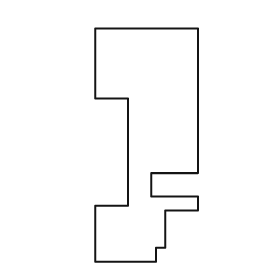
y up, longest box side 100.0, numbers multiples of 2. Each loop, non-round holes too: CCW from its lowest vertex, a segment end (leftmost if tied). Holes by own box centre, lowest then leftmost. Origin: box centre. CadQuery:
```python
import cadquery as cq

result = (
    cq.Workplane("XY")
    .moveTo(-22.0, -50.0)
    .lineTo(4.0, -50.0)
    .lineTo(4.0, -44.0)
    .lineTo(8.0, -44.0)
    .lineTo(8.0, -28.0)
    .lineTo(22.0, -28.0)
    .lineTo(22.0, -22.0)
    .lineTo(2.0, -22.0)
    .lineTo(2.0, -12.0)
    .lineTo(22.0, -12.0)
    .lineTo(22.0, 50.0)
    .lineTo(-22.0, 50.0)
    .lineTo(-22.0, 20.0)
    .lineTo(-8.0, 20.0)
    .lineTo(-8.0, -26.0)
    .lineTo(-22.0, -26.0)
    .close()
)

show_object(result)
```